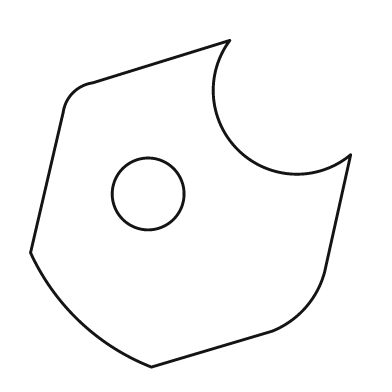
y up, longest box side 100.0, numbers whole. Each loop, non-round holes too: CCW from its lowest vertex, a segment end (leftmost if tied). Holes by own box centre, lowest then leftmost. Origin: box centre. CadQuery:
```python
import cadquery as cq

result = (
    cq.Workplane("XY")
    .moveTo(-12.0, -50.0)
    .lineTo(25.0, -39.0)
    .threePointArc((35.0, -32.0), (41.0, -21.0))
    .lineTo(49.0, 15.0)
    .threePointArc((15.0, 16.0), (12.0, 50.0))
    .lineTo(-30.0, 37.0)
    .threePointArc((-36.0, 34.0), (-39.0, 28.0))
    .lineTo(-49.0, -15.0)
    .threePointArc((-34.0, -36.0), (-12.0, -50.0))
    .close()
    .moveTo(-13.0, 3.0)
    .circle(11.0)
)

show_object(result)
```